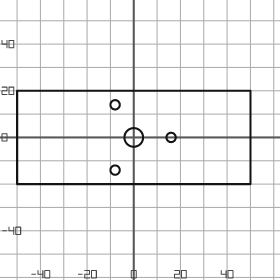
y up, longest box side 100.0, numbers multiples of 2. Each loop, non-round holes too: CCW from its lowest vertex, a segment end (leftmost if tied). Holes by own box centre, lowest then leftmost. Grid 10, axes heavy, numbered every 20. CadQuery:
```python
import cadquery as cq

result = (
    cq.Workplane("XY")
    .moveTo(-50.0, -20.0)
    .lineTo(50.0, -20.0)
    .lineTo(50.0, 20.0)
    .lineTo(-50.0, 20.0)
    .close()
    .moveTo(-8.0, -14.0)
    .circle(2.0)
    .moveTo(0.0, 0.0)
    .circle(4.0)
    .moveTo(16.0, 0.0)
    .circle(2.0)
    .moveTo(-8.0, 14.0)
    .circle(2.0)
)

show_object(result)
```